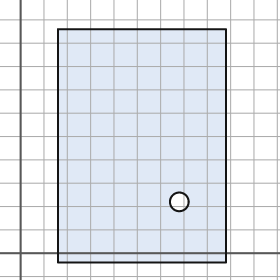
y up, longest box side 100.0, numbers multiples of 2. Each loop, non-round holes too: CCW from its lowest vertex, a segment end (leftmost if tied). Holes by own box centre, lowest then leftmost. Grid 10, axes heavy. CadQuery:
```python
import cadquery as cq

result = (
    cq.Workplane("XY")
    .moveTo(16.0, -4.0)
    .lineTo(88.0, -4.0)
    .lineTo(88.0, 96.0)
    .lineTo(16.0, 96.0)
    .close()
    .moveTo(68.0, 22.0)
    .circle(4.0)
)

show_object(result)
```